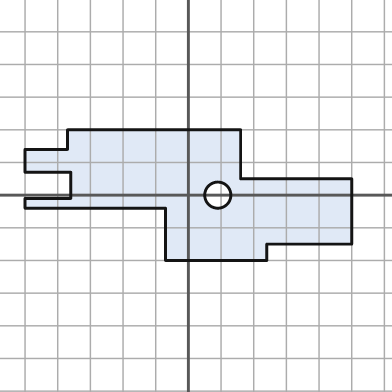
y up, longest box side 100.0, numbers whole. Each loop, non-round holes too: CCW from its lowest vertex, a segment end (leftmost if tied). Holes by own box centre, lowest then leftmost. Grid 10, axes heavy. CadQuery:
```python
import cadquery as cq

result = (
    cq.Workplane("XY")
    .moveTo(-7.0, -20.0)
    .lineTo(24.0, -20.0)
    .lineTo(24.0, -15.0)
    .lineTo(50.0, -15.0)
    .lineTo(50.0, 5.0)
    .lineTo(16.0, 5.0)
    .lineTo(16.0, 20.0)
    .lineTo(-37.0, 20.0)
    .lineTo(-37.0, 14.0)
    .lineTo(-50.0, 14.0)
    .lineTo(-50.0, 7.0)
    .lineTo(-36.0, 7.0)
    .lineTo(-36.0, -1.0)
    .lineTo(-50.0, -1.0)
    .lineTo(-50.0, -4.0)
    .lineTo(-7.0, -4.0)
    .close()
    .moveTo(9.0, 0.0)
    .circle(4.0)
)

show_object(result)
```